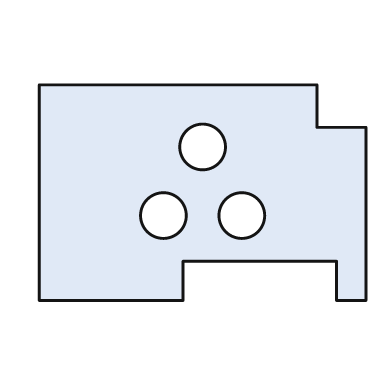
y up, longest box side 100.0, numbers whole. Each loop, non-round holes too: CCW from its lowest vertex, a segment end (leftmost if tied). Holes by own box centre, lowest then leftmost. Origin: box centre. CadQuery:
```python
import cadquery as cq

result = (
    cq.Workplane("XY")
    .moveTo(-50.0, -33.0)
    .lineTo(-6.0, -33.0)
    .lineTo(-6.0, -21.0)
    .lineTo(41.0, -21.0)
    .lineTo(41.0, -33.0)
    .lineTo(50.0, -33.0)
    .lineTo(50.0, 20.0)
    .lineTo(35.0, 20.0)
    .lineTo(35.0, 33.0)
    .lineTo(-50.0, 33.0)
    .close()
    .moveTo(-12.0, -7.0)
    .circle(7.0)
    .moveTo(12.0, -7.0)
    .circle(7.0)
    .moveTo(0.0, 14.0)
    .circle(7.0)
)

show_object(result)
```